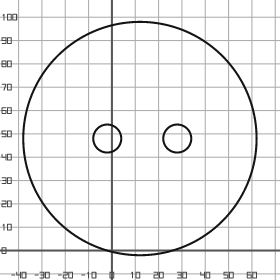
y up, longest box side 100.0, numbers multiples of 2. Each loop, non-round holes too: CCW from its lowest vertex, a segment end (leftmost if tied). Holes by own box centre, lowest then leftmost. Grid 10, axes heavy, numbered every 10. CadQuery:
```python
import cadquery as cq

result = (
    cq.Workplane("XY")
    .moveTo(12.0, 48.0)
    .circle(50.0)
    .moveTo(-2.0, 48.0)
    .circle(6.0)
    .moveTo(28.0, 48.0)
    .circle(6.0)
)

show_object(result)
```